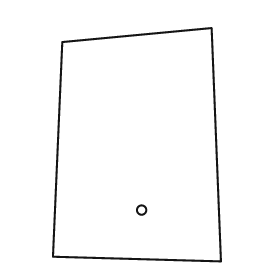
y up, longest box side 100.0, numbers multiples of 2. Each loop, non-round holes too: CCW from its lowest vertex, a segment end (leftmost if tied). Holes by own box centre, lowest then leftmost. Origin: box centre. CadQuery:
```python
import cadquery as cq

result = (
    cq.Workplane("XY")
    .moveTo(36.0, -50.0)
    .lineTo(32.0, 50.0)
    .lineTo(-32.0, 44.0)
    .lineTo(-36.0, -48.0)
    .close()
    .moveTo(2.0, -28.0)
    .circle(2.0)
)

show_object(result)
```